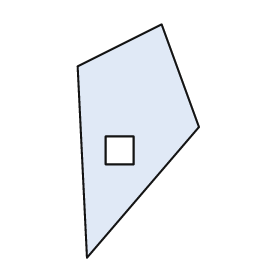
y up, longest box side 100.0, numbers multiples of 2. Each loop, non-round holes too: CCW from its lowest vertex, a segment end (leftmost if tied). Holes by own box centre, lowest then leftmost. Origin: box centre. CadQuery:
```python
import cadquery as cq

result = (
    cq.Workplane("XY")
    .moveTo(-22.0, -50.0)
    .lineTo(26.0, 6.0)
    .lineTo(10.0, 50.0)
    .lineTo(-26.0, 32.0)
    .close()
    .moveTo(-14.0, -10.0)
    .lineTo(-2.0, -10.0)
    .lineTo(-2.0, 2.0)
    .lineTo(-14.0, 2.0)
    .close()
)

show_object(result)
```